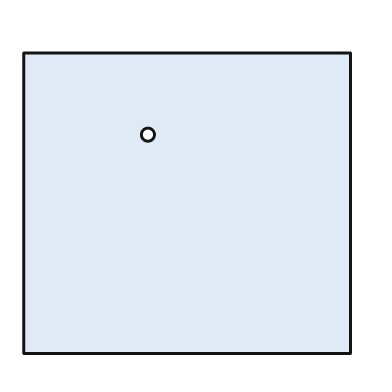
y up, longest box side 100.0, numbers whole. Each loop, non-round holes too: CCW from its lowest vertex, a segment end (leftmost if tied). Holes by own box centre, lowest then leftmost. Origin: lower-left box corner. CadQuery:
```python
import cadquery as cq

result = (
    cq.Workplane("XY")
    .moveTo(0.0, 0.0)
    .lineTo(100.0, 0.0)
    .lineTo(100.0, 92.0)
    .lineTo(0.0, 92.0)
    .close()
    .moveTo(38.0, 67.0)
    .circle(2.0)
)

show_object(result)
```